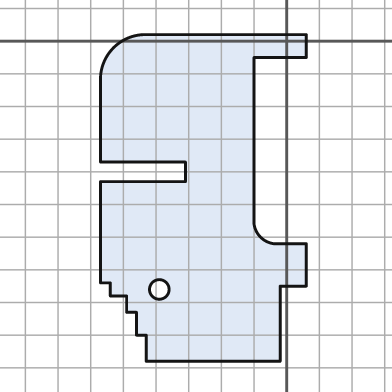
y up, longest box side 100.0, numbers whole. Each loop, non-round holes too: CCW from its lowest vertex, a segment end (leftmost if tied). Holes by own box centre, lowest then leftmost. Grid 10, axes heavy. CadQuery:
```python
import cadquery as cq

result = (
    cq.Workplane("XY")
    .moveTo(-43.0, -98.0)
    .lineTo(-2.0, -98.0)
    .lineTo(-2.0, -75.0)
    .lineTo(6.0, -75.0)
    .lineTo(6.0, -62.0)
    .lineTo(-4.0, -62.0)
    .threePointArc((-8.0, -60.0), (-10.0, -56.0))
    .lineTo(-10.0, -5.0)
    .lineTo(6.0, -5.0)
    .lineTo(6.0, 2.0)
    .lineTo(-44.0, 2.0)
    .threePointArc((-53.0, -2.0), (-57.0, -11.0))
    .lineTo(-57.0, -37.0)
    .lineTo(-31.0, -37.0)
    .lineTo(-31.0, -43.0)
    .lineTo(-57.0, -43.0)
    .lineTo(-57.0, -74.0)
    .lineTo(-54.0, -74.0)
    .lineTo(-54.0, -78.0)
    .lineTo(-49.0, -78.0)
    .lineTo(-49.0, -83.0)
    .lineTo(-46.0, -83.0)
    .lineTo(-46.0, -90.0)
    .lineTo(-43.0, -90.0)
    .close()
    .moveTo(-39.0, -76.0)
    .circle(3.0)
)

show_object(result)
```